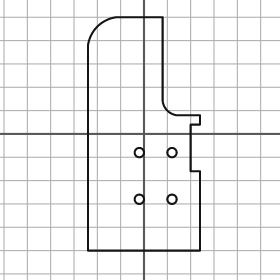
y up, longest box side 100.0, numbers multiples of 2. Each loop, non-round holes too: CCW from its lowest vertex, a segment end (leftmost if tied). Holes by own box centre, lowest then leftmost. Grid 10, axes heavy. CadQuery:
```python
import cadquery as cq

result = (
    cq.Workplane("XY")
    .moveTo(-24.0, -50.0)
    .lineTo(24.0, -50.0)
    .lineTo(24.0, -16.0)
    .lineTo(20.0, -16.0)
    .lineTo(20.0, 4.0)
    .lineTo(24.0, 4.0)
    .lineTo(24.0, 8.0)
    .lineTo(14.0, 8.0)
    .threePointArc((10.0, 10.0), (8.0, 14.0))
    .lineTo(8.0, 50.0)
    .lineTo(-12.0, 50.0)
    .threePointArc((-20.0, 46.0), (-24.0, 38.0))
    .close()
    .moveTo(-2.0, -28.0)
    .circle(2.0)
    .moveTo(12.0, -28.0)
    .circle(2.0)
    .moveTo(-2.0, -8.0)
    .circle(2.0)
    .moveTo(12.0, -8.0)
    .circle(2.0)
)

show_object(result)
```